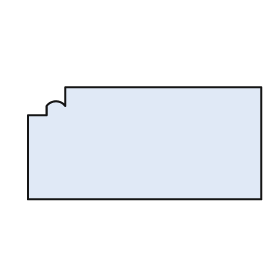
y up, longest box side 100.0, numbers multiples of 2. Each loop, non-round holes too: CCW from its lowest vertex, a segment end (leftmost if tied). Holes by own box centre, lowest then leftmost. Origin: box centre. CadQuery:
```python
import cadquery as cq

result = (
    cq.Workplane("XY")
    .moveTo(-50.0, -24.0)
    .lineTo(50.0, -24.0)
    .lineTo(50.0, 24.0)
    .lineTo(-34.0, 24.0)
    .lineTo(-34.0, 16.0)
    .threePointArc((-38.0, 18.0), (-42.0, 16.0))
    .lineTo(-42.0, 12.0)
    .lineTo(-50.0, 12.0)
    .close()
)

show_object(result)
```